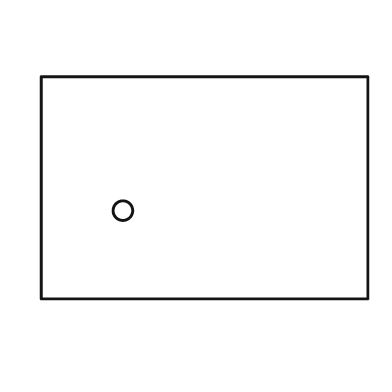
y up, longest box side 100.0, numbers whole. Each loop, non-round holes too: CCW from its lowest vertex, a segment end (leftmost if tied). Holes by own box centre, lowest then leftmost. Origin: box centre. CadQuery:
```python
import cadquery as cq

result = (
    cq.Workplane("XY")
    .moveTo(-50.0, -34.0)
    .lineTo(50.0, -34.0)
    .lineTo(50.0, 34.0)
    .lineTo(-50.0, 34.0)
    .close()
    .moveTo(-25.0, -7.0)
    .circle(3.0)
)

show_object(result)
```